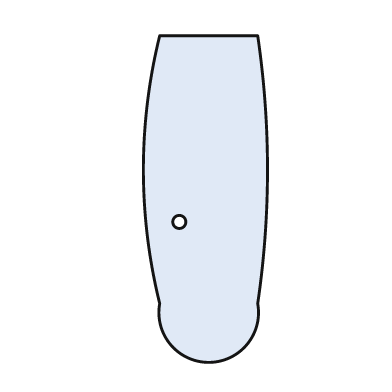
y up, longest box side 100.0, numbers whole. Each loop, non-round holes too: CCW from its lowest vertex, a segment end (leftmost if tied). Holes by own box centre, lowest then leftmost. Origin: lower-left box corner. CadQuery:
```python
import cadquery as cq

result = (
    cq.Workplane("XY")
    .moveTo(5.0, 18.0)
    .threePointArc((20.0, 0.0), (35.0, 18.0))
    .threePointArc((38.0, 59.0), (35.0, 100.0))
    .lineTo(5.0, 100.0)
    .threePointArc((0.0, 59.0), (5.0, 18.0))
    .close()
    .moveTo(11.0, 43.0)
    .circle(2.0)
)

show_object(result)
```